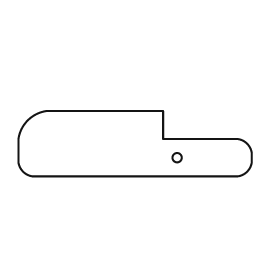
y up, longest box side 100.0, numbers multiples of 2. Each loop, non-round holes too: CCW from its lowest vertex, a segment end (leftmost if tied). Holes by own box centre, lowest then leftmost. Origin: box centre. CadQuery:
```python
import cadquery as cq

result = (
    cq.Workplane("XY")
    .moveTo(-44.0, -14.0)
    .lineTo(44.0, -14.0)
    .threePointArc((48.0, -12.0), (50.0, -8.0))
    .lineTo(50.0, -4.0)
    .threePointArc((48.0, 0.0), (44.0, 2.0))
    .lineTo(12.0, 2.0)
    .lineTo(12.0, 14.0)
    .lineTo(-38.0, 14.0)
    .threePointArc((-46.0, 10.0), (-50.0, 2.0))
    .lineTo(-50.0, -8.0)
    .threePointArc((-48.0, -12.0), (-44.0, -14.0))
    .close()
    .moveTo(18.0, -6.0)
    .circle(2.0)
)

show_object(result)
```